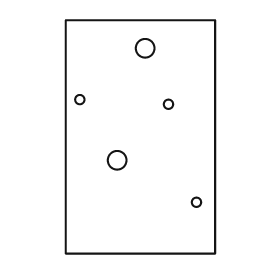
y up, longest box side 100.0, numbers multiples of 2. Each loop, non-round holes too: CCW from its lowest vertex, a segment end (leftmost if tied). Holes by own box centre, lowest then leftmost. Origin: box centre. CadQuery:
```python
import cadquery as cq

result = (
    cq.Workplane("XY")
    .moveTo(-32.0, -50.0)
    .lineTo(32.0, -50.0)
    .lineTo(32.0, 50.0)
    .lineTo(-32.0, 50.0)
    .close()
    .moveTo(24.0, -28.0)
    .circle(2.0)
    .moveTo(-10.0, -10.0)
    .circle(4.0)
    .moveTo(12.0, 14.0)
    .circle(2.0)
    .moveTo(-26.0, 16.0)
    .circle(2.0)
    .moveTo(2.0, 38.0)
    .circle(4.0)
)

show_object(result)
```